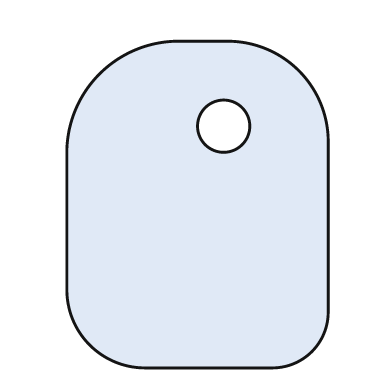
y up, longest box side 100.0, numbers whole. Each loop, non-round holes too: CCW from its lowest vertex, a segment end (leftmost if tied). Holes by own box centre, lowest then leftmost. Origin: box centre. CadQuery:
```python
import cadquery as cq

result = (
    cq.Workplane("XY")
    .moveTo(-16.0, -50.0)
    .lineTo(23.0, -50.0)
    .threePointArc((35.0, -45.0), (40.0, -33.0))
    .lineTo(40.0, 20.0)
    .threePointArc((31.0, 41.0), (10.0, 50.0))
    .lineTo(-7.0, 50.0)
    .threePointArc((-30.0, 40.0), (-40.0, 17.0))
    .lineTo(-40.0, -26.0)
    .threePointArc((-33.0, -43.0), (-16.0, -50.0))
    .close()
    .moveTo(8.0, 24.0)
    .circle(8.0)
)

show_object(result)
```